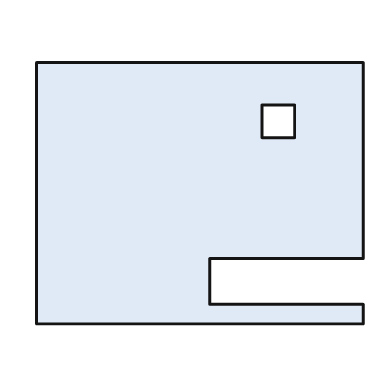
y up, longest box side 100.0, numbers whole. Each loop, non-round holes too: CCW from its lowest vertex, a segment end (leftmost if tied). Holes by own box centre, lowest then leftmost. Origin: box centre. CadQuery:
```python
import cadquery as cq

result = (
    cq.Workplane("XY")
    .moveTo(-50.0, -40.0)
    .lineTo(50.0, -40.0)
    .lineTo(50.0, -34.0)
    .lineTo(3.0, -34.0)
    .lineTo(3.0, -20.0)
    .lineTo(50.0, -20.0)
    .lineTo(50.0, 40.0)
    .lineTo(-50.0, 40.0)
    .close()
    .moveTo(19.0, 17.0)
    .lineTo(29.0, 17.0)
    .lineTo(29.0, 27.0)
    .lineTo(19.0, 27.0)
    .close()
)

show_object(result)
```